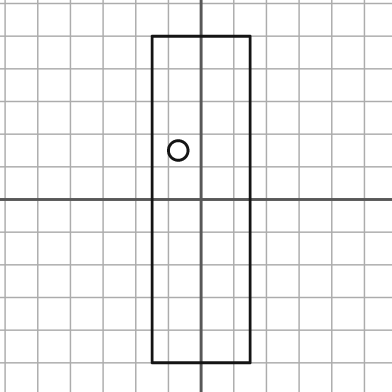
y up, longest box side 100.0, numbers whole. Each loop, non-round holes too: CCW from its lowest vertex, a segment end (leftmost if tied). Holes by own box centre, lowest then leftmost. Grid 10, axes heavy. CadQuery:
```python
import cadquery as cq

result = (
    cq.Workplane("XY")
    .moveTo(-15.0, -50.0)
    .lineTo(15.0, -50.0)
    .lineTo(15.0, 50.0)
    .lineTo(-15.0, 50.0)
    .close()
    .moveTo(-7.0, 15.0)
    .circle(3.0)
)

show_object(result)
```